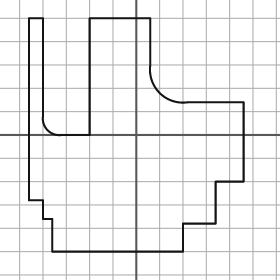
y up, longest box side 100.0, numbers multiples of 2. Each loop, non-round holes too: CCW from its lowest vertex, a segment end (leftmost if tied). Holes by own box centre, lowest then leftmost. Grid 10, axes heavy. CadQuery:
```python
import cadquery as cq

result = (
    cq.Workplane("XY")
    .moveTo(-36.0, -50.0)
    .lineTo(20.0, -50.0)
    .lineTo(20.0, -38.0)
    .lineTo(34.0, -38.0)
    .lineTo(34.0, -20.0)
    .lineTo(46.0, -20.0)
    .lineTo(46.0, 14.0)
    .lineTo(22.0, 14.0)
    .threePointArc((10.0, 18.0), (6.0, 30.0))
    .lineTo(6.0, 50.0)
    .lineTo(-20.0, 50.0)
    .lineTo(-20.0, 0.0)
    .lineTo(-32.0, 0.0)
    .threePointArc((-38.0, 2.0), (-40.0, 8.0))
    .lineTo(-40.0, 50.0)
    .lineTo(-46.0, 50.0)
    .lineTo(-46.0, -28.0)
    .lineTo(-40.0, -28.0)
    .lineTo(-40.0, -36.0)
    .lineTo(-36.0, -36.0)
    .close()
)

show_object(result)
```